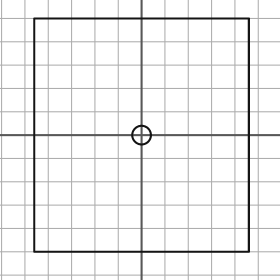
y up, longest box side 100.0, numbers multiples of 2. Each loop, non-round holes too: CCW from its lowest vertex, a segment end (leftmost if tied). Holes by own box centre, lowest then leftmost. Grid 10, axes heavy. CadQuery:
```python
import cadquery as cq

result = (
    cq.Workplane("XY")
    .moveTo(-46.0, -50.0)
    .lineTo(46.0, -50.0)
    .lineTo(46.0, 50.0)
    .lineTo(-46.0, 50.0)
    .close()
    .moveTo(0.0, 0.0)
    .circle(4.0)
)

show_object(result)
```